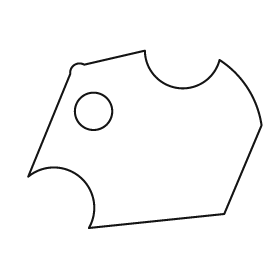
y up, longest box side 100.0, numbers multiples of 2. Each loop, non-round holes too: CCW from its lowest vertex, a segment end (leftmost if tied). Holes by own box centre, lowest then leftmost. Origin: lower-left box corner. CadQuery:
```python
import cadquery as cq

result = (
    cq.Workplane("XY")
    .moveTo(26.0, 0.0)
    .lineTo(84.0, 6.0)
    .lineTo(100.0, 44.0)
    .threePointArc((94.0, 60.0), (82.0, 72.0))
    .threePointArc((64.0, 60.0), (50.0, 76.0))
    .lineTo(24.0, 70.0)
    .threePointArc((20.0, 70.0), (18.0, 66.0))
    .lineTo(0.0, 22.0)
    .threePointArc((22.0, 22.0), (26.0, 0.0))
    .close()
    .moveTo(28.0, 50.0)
    .circle(8.0)
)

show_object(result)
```